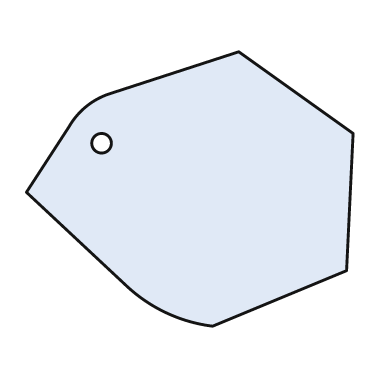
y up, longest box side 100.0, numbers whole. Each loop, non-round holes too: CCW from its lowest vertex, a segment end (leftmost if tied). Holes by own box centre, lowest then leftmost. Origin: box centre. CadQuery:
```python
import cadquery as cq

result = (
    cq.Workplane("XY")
    .moveTo(7.0, -42.0)
    .lineTo(48.0, -25.0)
    .lineTo(50.0, 17.0)
    .lineTo(15.0, 42.0)
    .lineTo(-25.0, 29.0)
    .threePointArc((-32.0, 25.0), (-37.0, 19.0))
    .lineTo(-50.0, -1.0)
    .lineTo(-19.0, -30.0)
    .threePointArc((-7.0, -38.0), (7.0, -42.0))
    .close()
    .moveTo(-27.0, 14.0)
    .circle(3.0)
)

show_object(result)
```